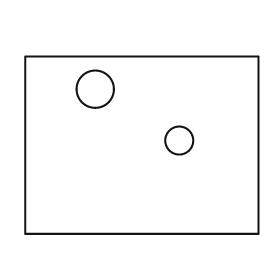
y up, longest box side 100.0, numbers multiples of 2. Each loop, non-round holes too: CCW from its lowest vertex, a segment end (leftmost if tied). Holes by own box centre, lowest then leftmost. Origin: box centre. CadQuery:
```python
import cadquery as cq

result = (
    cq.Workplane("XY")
    .moveTo(-50.0, -38.0)
    .lineTo(50.0, -38.0)
    .lineTo(50.0, 38.0)
    .lineTo(-50.0, 38.0)
    .close()
    .moveTo(16.0, 2.0)
    .circle(6.0)
    .moveTo(-20.0, 24.0)
    .circle(8.0)
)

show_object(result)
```